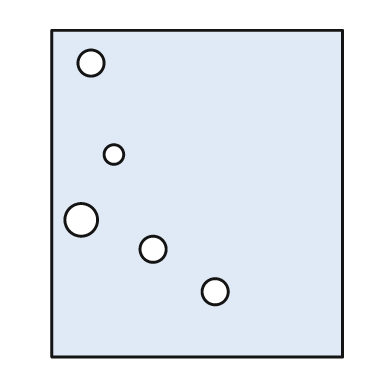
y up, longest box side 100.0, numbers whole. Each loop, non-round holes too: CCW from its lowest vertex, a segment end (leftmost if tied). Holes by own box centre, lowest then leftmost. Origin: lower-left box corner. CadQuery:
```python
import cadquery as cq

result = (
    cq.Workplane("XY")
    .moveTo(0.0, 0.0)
    .lineTo(89.0, 0.0)
    .lineTo(89.0, 100.0)
    .lineTo(0.0, 100.0)
    .close()
    .moveTo(50.0, 20.0)
    .circle(4.0)
    .moveTo(31.0, 33.0)
    .circle(4.0)
    .moveTo(9.0, 42.0)
    .circle(5.0)
    .moveTo(19.0, 62.0)
    .circle(3.0)
    .moveTo(12.0, 90.0)
    .circle(4.0)
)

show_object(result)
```